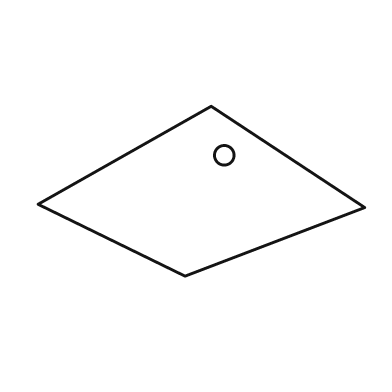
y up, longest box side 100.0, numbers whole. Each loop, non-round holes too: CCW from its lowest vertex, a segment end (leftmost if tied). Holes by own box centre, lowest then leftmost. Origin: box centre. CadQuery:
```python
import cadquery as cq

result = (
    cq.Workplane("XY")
    .moveTo(-5.0, -26.0)
    .lineTo(50.0, -5.0)
    .lineTo(3.0, 26.0)
    .lineTo(-50.0, -4.0)
    .close()
    .moveTo(7.0, 11.0)
    .circle(3.0)
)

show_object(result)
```